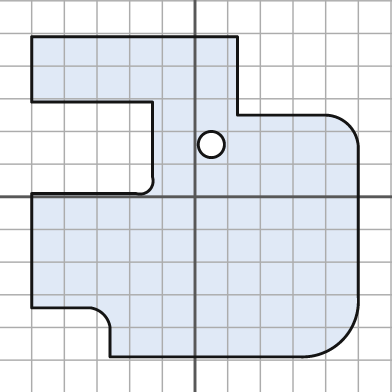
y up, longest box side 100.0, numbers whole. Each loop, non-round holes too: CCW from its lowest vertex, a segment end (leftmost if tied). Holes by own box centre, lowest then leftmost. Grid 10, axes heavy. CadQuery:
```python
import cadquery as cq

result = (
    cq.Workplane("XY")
    .moveTo(-26.0, -49.0)
    .lineTo(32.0, -49.0)
    .threePointArc((45.0, -44.0), (50.0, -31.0))
    .lineTo(50.0, 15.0)
    .threePointArc((47.0, 22.0), (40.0, 25.0))
    .lineTo(13.0, 25.0)
    .lineTo(13.0, 49.0)
    .lineTo(-50.0, 49.0)
    .lineTo(-50.0, 29.0)
    .lineTo(-13.0, 29.0)
    .lineTo(-13.0, 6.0)
    .threePointArc((-14.0, 2.0), (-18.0, 1.0))
    .lineTo(-50.0, 1.0)
    .lineTo(-50.0, -34.0)
    .lineTo(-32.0, -34.0)
    .threePointArc((-28.0, -36.0), (-26.0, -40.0))
    .close()
    .moveTo(5.0, 16.0)
    .circle(4.0)
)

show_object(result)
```